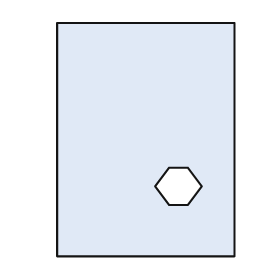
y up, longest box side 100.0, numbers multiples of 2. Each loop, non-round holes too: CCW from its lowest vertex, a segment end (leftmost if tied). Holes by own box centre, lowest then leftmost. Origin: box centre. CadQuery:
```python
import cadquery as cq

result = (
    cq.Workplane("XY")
    .moveTo(-38.0, -50.0)
    .lineTo(38.0, -50.0)
    .lineTo(38.0, 50.0)
    .lineTo(-38.0, 50.0)
    .close()
    .moveTo(10.0, -28.0)
    .lineTo(18.0, -28.0)
    .lineTo(24.0, -20.0)
    .lineTo(18.0, -12.0)
    .lineTo(10.0, -12.0)
    .lineTo(4.0, -20.0)
    .close()
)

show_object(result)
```